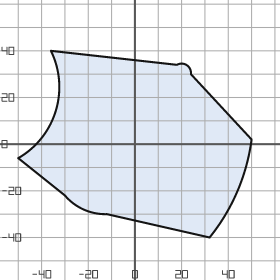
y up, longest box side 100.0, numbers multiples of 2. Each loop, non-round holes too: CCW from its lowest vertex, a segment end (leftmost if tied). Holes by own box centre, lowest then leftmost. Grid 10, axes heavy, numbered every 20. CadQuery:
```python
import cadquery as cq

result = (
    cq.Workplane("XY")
    .moveTo(32.0, -40.0)
    .threePointArc((44.0, -20.0), (50.0, 2.0))
    .lineTo(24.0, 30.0)
    .threePointArc((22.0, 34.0), (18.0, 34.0))
    .lineTo(-36.0, 40.0)
    .threePointArc((-34.0, 14.0), (-50.0, -6.0))
    .lineTo(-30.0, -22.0)
    .threePointArc((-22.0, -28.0), (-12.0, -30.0))
    .close()
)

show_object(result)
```